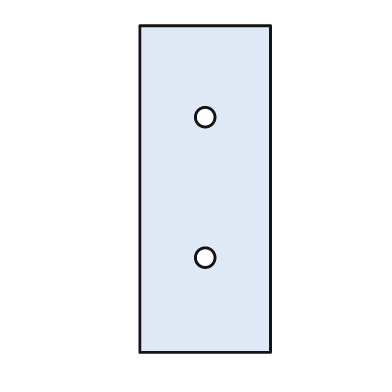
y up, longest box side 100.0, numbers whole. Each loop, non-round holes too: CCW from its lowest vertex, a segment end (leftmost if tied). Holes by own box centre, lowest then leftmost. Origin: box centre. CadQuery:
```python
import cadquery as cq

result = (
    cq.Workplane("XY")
    .moveTo(-20.0, -50.0)
    .lineTo(20.0, -50.0)
    .lineTo(20.0, 50.0)
    .lineTo(-20.0, 50.0)
    .close()
    .moveTo(0.0, -21.0)
    .circle(3.0)
    .moveTo(0.0, 22.0)
    .circle(3.0)
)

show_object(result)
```